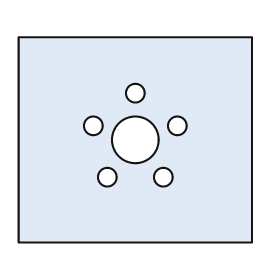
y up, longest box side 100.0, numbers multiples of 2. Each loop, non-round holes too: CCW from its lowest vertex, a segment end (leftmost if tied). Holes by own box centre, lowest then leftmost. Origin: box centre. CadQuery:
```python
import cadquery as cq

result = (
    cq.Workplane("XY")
    .moveTo(-50.0, -44.0)
    .lineTo(50.0, -44.0)
    .lineTo(50.0, 44.0)
    .lineTo(-50.0, 44.0)
    .close()
    .moveTo(-12.0, -16.0)
    .circle(4.0)
    .moveTo(12.0, -16.0)
    .circle(4.0)
    .moveTo(0.0, 0.0)
    .circle(10.0)
    .moveTo(-18.0, 6.0)
    .circle(4.0)
    .moveTo(18.0, 6.0)
    .circle(4.0)
    .moveTo(0.0, 20.0)
    .circle(4.0)
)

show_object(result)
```